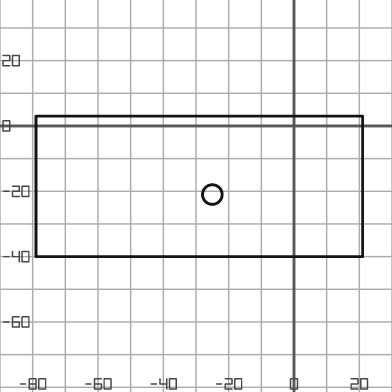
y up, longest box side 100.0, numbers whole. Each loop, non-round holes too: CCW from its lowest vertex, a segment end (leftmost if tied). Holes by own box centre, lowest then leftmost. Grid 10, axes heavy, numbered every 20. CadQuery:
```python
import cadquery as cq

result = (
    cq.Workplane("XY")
    .moveTo(-79.0, -40.0)
    .lineTo(21.0, -40.0)
    .lineTo(21.0, 3.0)
    .lineTo(-79.0, 3.0)
    .close()
    .moveTo(-25.0, -21.0)
    .circle(3.0)
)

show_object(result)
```